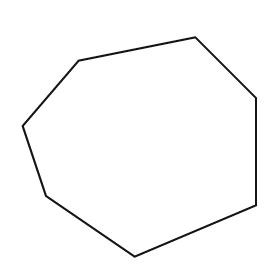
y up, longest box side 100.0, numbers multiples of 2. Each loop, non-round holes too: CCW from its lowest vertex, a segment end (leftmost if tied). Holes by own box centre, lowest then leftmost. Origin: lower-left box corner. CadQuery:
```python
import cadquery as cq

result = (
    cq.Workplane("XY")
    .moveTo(48.0, 0.0)
    .lineTo(100.0, 22.0)
    .lineTo(100.0, 68.0)
    .lineTo(74.0, 94.0)
    .lineTo(24.0, 84.0)
    .lineTo(0.0, 56.0)
    .lineTo(10.0, 26.0)
    .close()
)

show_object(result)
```